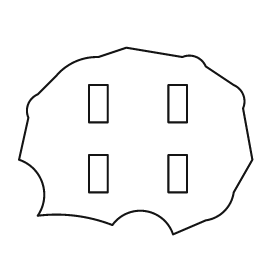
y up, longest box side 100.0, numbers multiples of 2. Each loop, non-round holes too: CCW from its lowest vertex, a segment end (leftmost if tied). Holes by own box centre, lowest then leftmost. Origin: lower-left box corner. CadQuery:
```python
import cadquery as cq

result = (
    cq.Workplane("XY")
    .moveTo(66.0, 0.0)
    .lineTo(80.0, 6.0)
    .threePointArc((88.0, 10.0), (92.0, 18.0))
    .lineTo(100.0, 32.0)
    .lineTo(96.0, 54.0)
    .threePointArc((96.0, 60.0), (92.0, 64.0))
    .lineTo(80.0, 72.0)
    .threePointArc((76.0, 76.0), (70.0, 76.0))
    .lineTo(46.0, 80.0)
    .lineTo(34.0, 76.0)
    .threePointArc((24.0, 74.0), (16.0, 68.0))
    .lineTo(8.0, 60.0)
    .threePointArc((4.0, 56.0), (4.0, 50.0))
    .lineTo(0.0, 32.0)
    .threePointArc((10.0, 22.0), (8.0, 8.0))
    .threePointArc((24.0, 8.0), (40.0, 4.0))
    .threePointArc((54.0, 10.0), (66.0, 0.0))
    .close()
    .moveTo(30.0, 18.0)
    .lineTo(38.0, 18.0)
    .lineTo(38.0, 34.0)
    .lineTo(30.0, 34.0)
    .close()
    .moveTo(64.0, 18.0)
    .lineTo(72.0, 18.0)
    .lineTo(72.0, 34.0)
    .lineTo(64.0, 34.0)
    .close()
    .moveTo(30.0, 48.0)
    .lineTo(38.0, 48.0)
    .lineTo(38.0, 64.0)
    .lineTo(30.0, 64.0)
    .close()
    .moveTo(64.0, 48.0)
    .lineTo(72.0, 48.0)
    .lineTo(72.0, 64.0)
    .lineTo(64.0, 64.0)
    .close()
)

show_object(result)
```